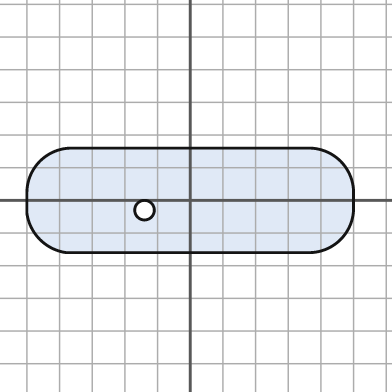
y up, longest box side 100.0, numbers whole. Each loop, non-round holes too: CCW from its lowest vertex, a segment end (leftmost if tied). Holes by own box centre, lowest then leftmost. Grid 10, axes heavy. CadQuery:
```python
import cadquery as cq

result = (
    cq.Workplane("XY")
    .moveTo(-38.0, -16.0)
    .lineTo(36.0, -16.0)
    .threePointArc((46.0, -12.0), (50.0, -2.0))
    .lineTo(50.0, 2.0)
    .threePointArc((46.0, 12.0), (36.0, 16.0))
    .lineTo(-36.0, 16.0)
    .threePointArc((-46.0, 12.0), (-50.0, 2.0))
    .lineTo(-50.0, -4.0)
    .threePointArc((-46.0, -12.0), (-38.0, -16.0))
    .close()
    .moveTo(-14.0, -3.0)
    .circle(3.0)
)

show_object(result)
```